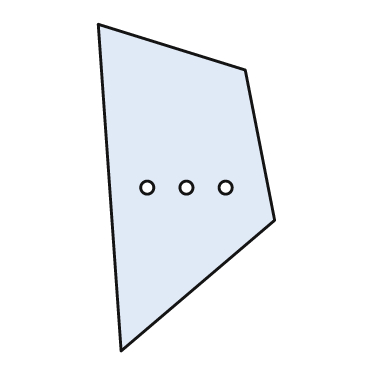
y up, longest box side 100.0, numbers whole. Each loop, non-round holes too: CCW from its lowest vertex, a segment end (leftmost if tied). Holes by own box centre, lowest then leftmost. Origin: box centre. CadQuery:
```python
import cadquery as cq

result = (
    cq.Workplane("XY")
    .moveTo(-20.0, -50.0)
    .lineTo(27.0, -10.0)
    .lineTo(18.0, 36.0)
    .lineTo(-27.0, 50.0)
    .close()
    .moveTo(-12.0, 0.0)
    .circle(2.0)
    .moveTo(0.0, 0.0)
    .circle(2.0)
    .moveTo(12.0, 0.0)
    .circle(2.0)
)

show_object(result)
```